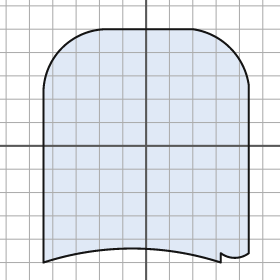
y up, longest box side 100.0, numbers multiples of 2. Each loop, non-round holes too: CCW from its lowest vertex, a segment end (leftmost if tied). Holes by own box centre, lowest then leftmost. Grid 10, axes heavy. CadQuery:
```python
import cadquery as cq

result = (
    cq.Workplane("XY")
    .moveTo(-44.0, -50.0)
    .threePointArc((-6.0, -44.0), (32.0, -50.0))
    .lineTo(32.0, -46.0)
    .threePointArc((38.0, -48.0), (44.0, -46.0))
    .lineTo(44.0, 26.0)
    .threePointArc((36.0, 42.0), (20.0, 50.0))
    .lineTo(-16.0, 50.0)
    .threePointArc((-36.0, 42.0), (-44.0, 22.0))
    .close()
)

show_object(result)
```